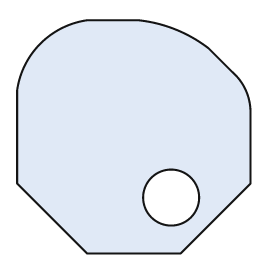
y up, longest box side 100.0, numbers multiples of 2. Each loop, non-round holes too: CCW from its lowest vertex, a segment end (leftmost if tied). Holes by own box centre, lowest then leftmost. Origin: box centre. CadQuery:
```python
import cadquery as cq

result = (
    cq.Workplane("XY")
    .moveTo(-20.0, -50.0)
    .lineTo(20.0, -50.0)
    .lineTo(50.0, -20.0)
    .lineTo(50.0, 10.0)
    .threePointArc((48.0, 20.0), (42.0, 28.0))
    .lineTo(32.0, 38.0)
    .threePointArc((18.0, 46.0), (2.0, 50.0))
    .lineTo(-20.0, 50.0)
    .threePointArc((-40.0, 40.0), (-50.0, 20.0))
    .lineTo(-50.0, -20.0)
    .close()
    .moveTo(16.0, -26.0)
    .circle(12.0)
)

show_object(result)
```